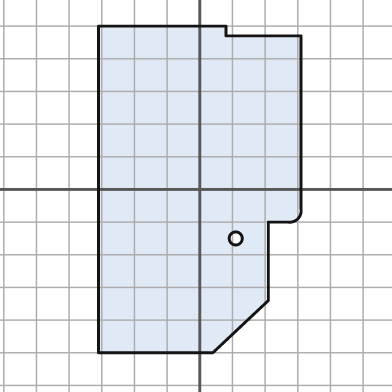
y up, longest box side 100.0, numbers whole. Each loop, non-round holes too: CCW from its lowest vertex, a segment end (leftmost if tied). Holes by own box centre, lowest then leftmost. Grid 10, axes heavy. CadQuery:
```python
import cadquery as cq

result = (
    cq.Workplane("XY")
    .moveTo(-31.0, -50.0)
    .lineTo(4.0, -50.0)
    .lineTo(21.0, -34.0)
    .lineTo(21.0, -10.0)
    .lineTo(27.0, -10.0)
    .threePointArc((30.0, -9.0), (31.0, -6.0))
    .lineTo(31.0, 47.0)
    .lineTo(8.0, 47.0)
    .lineTo(8.0, 50.0)
    .lineTo(-31.0, 50.0)
    .close()
    .moveTo(11.0, -15.0)
    .circle(2.0)
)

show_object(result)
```